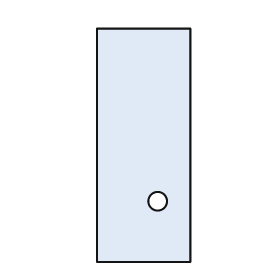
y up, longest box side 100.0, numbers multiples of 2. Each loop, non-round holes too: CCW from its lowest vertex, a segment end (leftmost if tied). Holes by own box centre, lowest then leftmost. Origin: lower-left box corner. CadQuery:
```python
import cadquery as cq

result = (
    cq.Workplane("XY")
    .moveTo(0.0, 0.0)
    .lineTo(40.0, 0.0)
    .lineTo(40.0, 100.0)
    .lineTo(0.0, 100.0)
    .close()
    .moveTo(26.0, 26.0)
    .circle(4.0)
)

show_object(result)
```